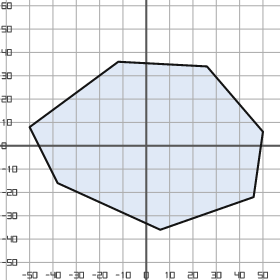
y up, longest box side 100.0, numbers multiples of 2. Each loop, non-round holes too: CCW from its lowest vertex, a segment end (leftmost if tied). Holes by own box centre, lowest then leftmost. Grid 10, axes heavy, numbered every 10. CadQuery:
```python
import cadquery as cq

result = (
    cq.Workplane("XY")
    .moveTo(6.0, -36.0)
    .lineTo(46.0, -22.0)
    .lineTo(50.0, 6.0)
    .lineTo(26.0, 34.0)
    .lineTo(-12.0, 36.0)
    .lineTo(-50.0, 8.0)
    .lineTo(-38.0, -16.0)
    .close()
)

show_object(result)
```